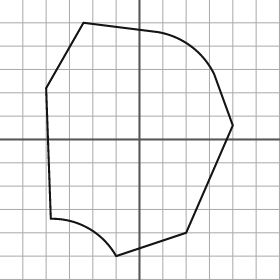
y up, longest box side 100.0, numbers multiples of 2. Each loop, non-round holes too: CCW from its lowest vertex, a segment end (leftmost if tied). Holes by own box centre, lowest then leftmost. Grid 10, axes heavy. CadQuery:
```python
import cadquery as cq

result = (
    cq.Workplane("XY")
    .moveTo(-10.0, -50.0)
    .lineTo(20.0, -40.0)
    .lineTo(40.0, 6.0)
    .lineTo(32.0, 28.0)
    .threePointArc((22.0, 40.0), (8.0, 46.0))
    .lineTo(-24.0, 50.0)
    .lineTo(-40.0, 22.0)
    .lineTo(-38.0, -34.0)
    .threePointArc((-22.0, -38.0), (-10.0, -50.0))
    .close()
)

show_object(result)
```